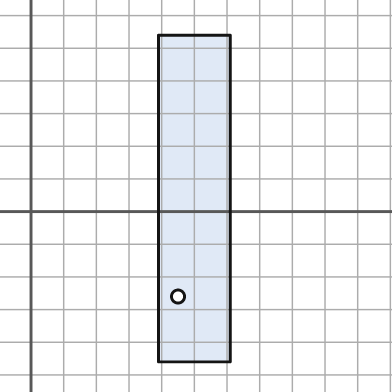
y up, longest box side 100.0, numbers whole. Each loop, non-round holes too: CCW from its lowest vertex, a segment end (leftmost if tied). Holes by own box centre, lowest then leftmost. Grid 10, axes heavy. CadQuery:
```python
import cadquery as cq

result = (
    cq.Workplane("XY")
    .moveTo(39.0, -46.0)
    .lineTo(61.0, -46.0)
    .lineTo(61.0, 54.0)
    .lineTo(39.0, 54.0)
    .close()
    .moveTo(45.0, -26.0)
    .circle(2.0)
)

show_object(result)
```